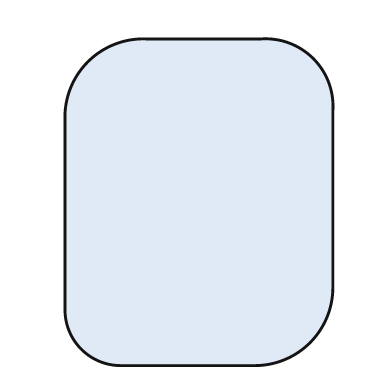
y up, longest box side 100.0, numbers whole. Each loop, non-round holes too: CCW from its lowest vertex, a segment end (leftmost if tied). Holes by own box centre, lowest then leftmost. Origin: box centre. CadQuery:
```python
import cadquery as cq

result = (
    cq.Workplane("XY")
    .moveTo(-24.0, -50.0)
    .lineTo(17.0, -50.0)
    .threePointArc((34.0, -43.0), (41.0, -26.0))
    .lineTo(41.0, 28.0)
    .threePointArc((35.0, 44.0), (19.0, 50.0))
    .lineTo(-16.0, 50.0)
    .threePointArc((-34.0, 43.0), (-41.0, 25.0))
    .lineTo(-41.0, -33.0)
    .threePointArc((-36.0, -45.0), (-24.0, -50.0))
    .close()
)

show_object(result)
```